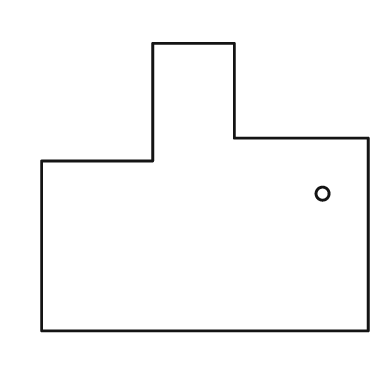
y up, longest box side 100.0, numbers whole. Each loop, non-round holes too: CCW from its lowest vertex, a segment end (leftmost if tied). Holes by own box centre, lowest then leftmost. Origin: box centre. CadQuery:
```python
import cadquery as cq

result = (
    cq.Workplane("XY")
    .moveTo(-50.0, -44.0)
    .lineTo(50.0, -44.0)
    .lineTo(50.0, 15.0)
    .lineTo(9.0, 15.0)
    .lineTo(9.0, 44.0)
    .lineTo(-16.0, 44.0)
    .lineTo(-16.0, 8.0)
    .lineTo(-50.0, 8.0)
    .close()
    .moveTo(36.0, -2.0)
    .circle(2.0)
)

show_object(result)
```